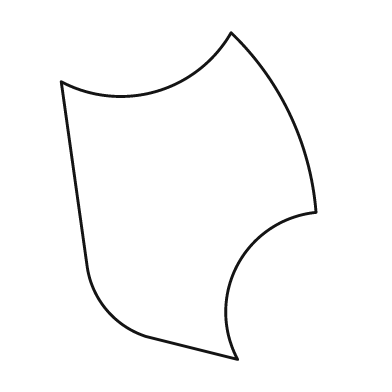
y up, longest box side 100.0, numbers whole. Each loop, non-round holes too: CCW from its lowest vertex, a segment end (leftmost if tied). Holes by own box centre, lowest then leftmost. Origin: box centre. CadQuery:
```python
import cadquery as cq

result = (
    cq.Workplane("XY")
    .moveTo(15.0, -50.0)
    .threePointArc((15.0, -21.0), (39.0, -5.0))
    .threePointArc((31.0, 25.0), (13.0, 50.0))
    .threePointArc((-10.0, 32.0), (-39.0, 35.0))
    .lineTo(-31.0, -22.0)
    .threePointArc((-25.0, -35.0), (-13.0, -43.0))
    .close()
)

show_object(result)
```